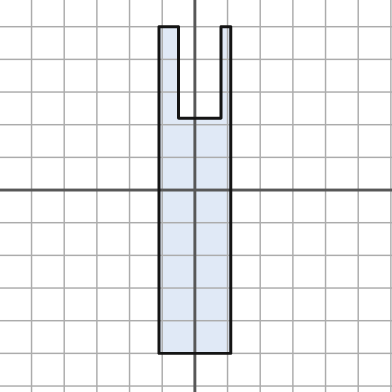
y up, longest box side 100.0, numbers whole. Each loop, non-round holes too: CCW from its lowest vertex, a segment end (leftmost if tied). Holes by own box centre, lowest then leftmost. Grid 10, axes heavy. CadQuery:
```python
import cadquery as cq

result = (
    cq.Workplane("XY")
    .moveTo(-11.0, -50.0)
    .lineTo(11.0, -50.0)
    .lineTo(11.0, 50.0)
    .lineTo(8.0, 50.0)
    .lineTo(8.0, 22.0)
    .lineTo(-5.0, 22.0)
    .lineTo(-5.0, 50.0)
    .lineTo(-11.0, 50.0)
    .close()
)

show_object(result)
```